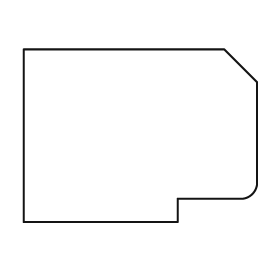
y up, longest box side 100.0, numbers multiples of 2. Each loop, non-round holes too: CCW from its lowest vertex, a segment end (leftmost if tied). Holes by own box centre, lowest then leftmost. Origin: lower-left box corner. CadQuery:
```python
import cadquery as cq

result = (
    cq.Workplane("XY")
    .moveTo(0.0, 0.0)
    .lineTo(66.0, 0.0)
    .lineTo(66.0, 10.0)
    .lineTo(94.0, 10.0)
    .threePointArc((98.0, 12.0), (100.0, 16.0))
    .lineTo(100.0, 60.0)
    .lineTo(86.0, 74.0)
    .lineTo(0.0, 74.0)
    .close()
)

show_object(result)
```